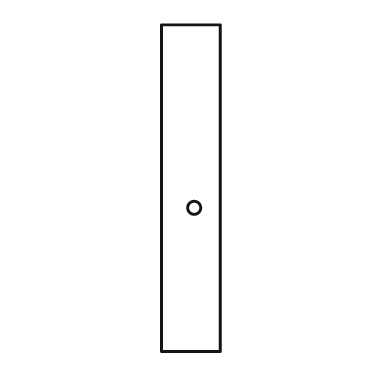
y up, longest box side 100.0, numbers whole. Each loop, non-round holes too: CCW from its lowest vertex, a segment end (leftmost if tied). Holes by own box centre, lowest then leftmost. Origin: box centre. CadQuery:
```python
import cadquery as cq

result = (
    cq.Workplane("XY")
    .moveTo(-9.0, -50.0)
    .lineTo(9.0, -50.0)
    .lineTo(9.0, 50.0)
    .lineTo(-9.0, 50.0)
    .close()
    .moveTo(1.0, -6.0)
    .circle(2.0)
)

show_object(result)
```